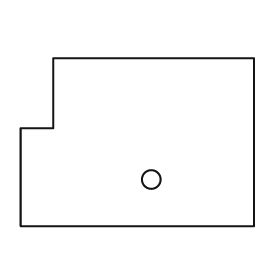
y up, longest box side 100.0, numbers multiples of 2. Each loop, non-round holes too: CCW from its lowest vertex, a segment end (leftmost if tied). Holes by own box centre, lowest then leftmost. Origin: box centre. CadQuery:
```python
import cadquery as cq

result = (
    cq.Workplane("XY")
    .moveTo(-50.0, -36.0)
    .lineTo(50.0, -36.0)
    .lineTo(50.0, 36.0)
    .lineTo(-36.0, 36.0)
    .lineTo(-36.0, 6.0)
    .lineTo(-50.0, 6.0)
    .close()
    .moveTo(6.0, -16.0)
    .circle(4.0)
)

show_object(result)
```